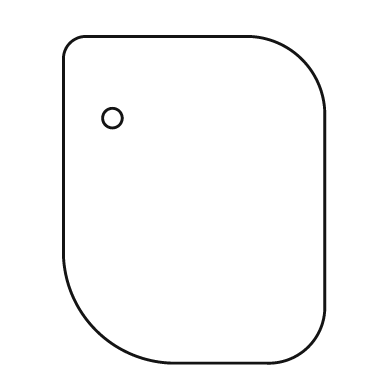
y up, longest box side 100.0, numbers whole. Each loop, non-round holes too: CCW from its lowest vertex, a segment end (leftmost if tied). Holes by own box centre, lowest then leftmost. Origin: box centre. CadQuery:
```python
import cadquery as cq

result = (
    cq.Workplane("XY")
    .moveTo(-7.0, -50.0)
    .lineTo(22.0, -50.0)
    .threePointArc((35.0, -45.0), (40.0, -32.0))
    .lineTo(40.0, 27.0)
    .threePointArc((33.0, 43.0), (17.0, 50.0))
    .lineTo(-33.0, 50.0)
    .threePointArc((-38.0, 48.0), (-40.0, 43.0))
    .lineTo(-40.0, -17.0)
    .threePointArc((-30.0, -40.0), (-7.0, -50.0))
    .close()
    .moveTo(-25.0, 25.0)
    .circle(3.0)
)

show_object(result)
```